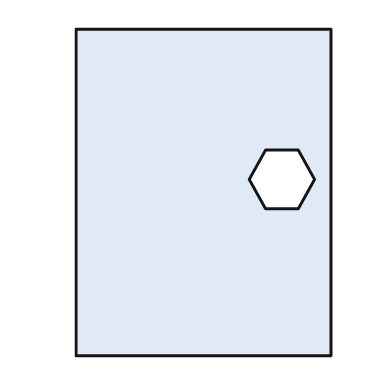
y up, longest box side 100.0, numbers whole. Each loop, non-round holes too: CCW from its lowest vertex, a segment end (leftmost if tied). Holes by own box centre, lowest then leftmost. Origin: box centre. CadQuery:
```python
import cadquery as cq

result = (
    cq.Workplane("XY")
    .moveTo(-39.0, -50.0)
    .lineTo(39.0, -50.0)
    .lineTo(39.0, 50.0)
    .lineTo(-39.0, 50.0)
    .close()
    .moveTo(19.0, -5.0)
    .lineTo(29.0, -5.0)
    .lineTo(34.0, 4.0)
    .lineTo(29.0, 13.0)
    .lineTo(19.0, 13.0)
    .lineTo(14.0, 4.0)
    .close()
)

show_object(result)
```